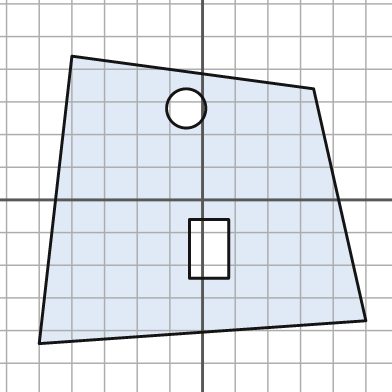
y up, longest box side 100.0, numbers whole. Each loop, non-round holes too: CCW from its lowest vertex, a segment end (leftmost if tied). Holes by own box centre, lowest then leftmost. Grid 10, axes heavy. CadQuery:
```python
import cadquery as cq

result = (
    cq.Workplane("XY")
    .moveTo(-50.0, -44.0)
    .lineTo(50.0, -37.0)
    .lineTo(34.0, 34.0)
    .lineTo(-40.0, 44.0)
    .close()
    .moveTo(-4.0, -24.0)
    .lineTo(8.0, -24.0)
    .lineTo(8.0, -6.0)
    .lineTo(-4.0, -6.0)
    .close()
    .moveTo(-5.0, 28.0)
    .circle(6.0)
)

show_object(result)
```